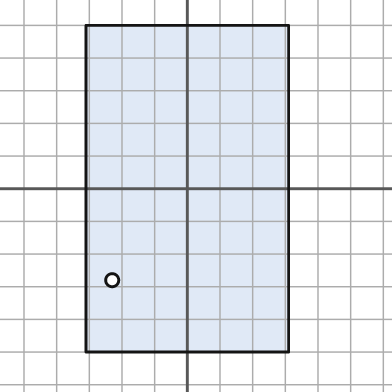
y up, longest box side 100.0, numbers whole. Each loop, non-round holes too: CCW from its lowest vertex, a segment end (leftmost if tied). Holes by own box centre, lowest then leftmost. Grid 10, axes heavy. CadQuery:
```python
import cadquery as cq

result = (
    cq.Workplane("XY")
    .moveTo(-31.0, -50.0)
    .lineTo(31.0, -50.0)
    .lineTo(31.0, 50.0)
    .lineTo(-31.0, 50.0)
    .close()
    .moveTo(-23.0, -28.0)
    .circle(2.0)
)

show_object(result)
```